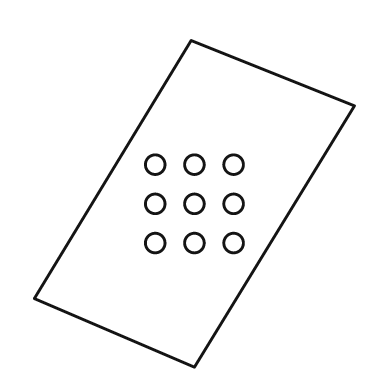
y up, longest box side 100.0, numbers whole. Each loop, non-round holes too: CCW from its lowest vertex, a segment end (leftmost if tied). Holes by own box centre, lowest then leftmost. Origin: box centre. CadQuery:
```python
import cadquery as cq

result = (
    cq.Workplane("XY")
    .moveTo(0.0, -50.0)
    .lineTo(49.0, 30.0)
    .lineTo(-1.0, 50.0)
    .lineTo(-49.0, -29.0)
    .close()
    .moveTo(-12.0, -12.0)
    .circle(3.0)
    .moveTo(0.0, -12.0)
    .circle(3.0)
    .moveTo(12.0, -12.0)
    .circle(3.0)
    .moveTo(-12.0, 0.0)
    .circle(3.0)
    .moveTo(0.0, 0.0)
    .circle(3.0)
    .moveTo(12.0, 0.0)
    .circle(3.0)
    .moveTo(-12.0, 12.0)
    .circle(3.0)
    .moveTo(0.0, 12.0)
    .circle(3.0)
    .moveTo(12.0, 12.0)
    .circle(3.0)
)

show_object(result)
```